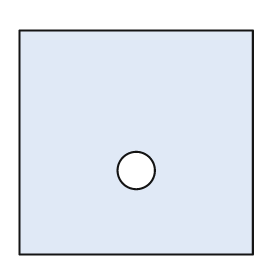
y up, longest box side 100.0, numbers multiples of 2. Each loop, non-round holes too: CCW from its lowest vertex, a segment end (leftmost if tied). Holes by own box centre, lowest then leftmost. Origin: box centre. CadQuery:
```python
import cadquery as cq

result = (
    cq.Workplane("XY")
    .moveTo(-50.0, -48.0)
    .lineTo(50.0, -48.0)
    .lineTo(50.0, 48.0)
    .lineTo(-50.0, 48.0)
    .close()
    .moveTo(0.0, -12.0)
    .circle(8.0)
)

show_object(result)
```